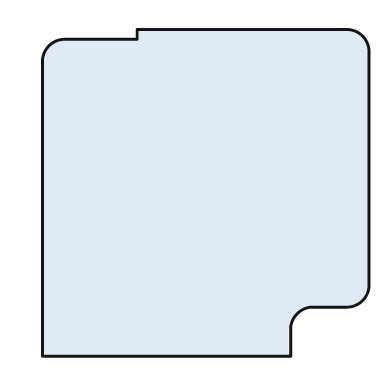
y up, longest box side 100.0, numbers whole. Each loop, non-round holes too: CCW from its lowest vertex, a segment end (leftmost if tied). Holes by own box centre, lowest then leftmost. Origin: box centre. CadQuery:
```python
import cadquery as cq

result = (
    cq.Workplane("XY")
    .moveTo(-50.0, -50.0)
    .lineTo(26.0, -50.0)
    .lineTo(26.0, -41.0)
    .threePointArc((28.0, -37.0), (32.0, -35.0))
    .lineTo(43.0, -35.0)
    .threePointArc((48.0, -33.0), (50.0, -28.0))
    .lineTo(50.0, 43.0)
    .threePointArc((48.0, 48.0), (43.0, 50.0))
    .lineTo(-21.0, 50.0)
    .lineTo(-21.0, 47.0)
    .lineTo(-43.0, 47.0)
    .threePointArc((-48.0, 45.0), (-50.0, 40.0))
    .close()
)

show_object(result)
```